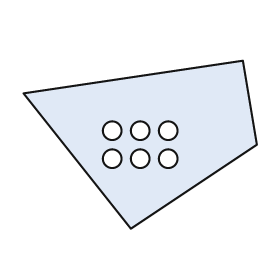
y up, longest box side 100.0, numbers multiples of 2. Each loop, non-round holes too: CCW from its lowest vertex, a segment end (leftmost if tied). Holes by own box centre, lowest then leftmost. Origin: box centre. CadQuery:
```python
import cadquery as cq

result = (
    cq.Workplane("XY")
    .moveTo(-4.0, -36.0)
    .lineTo(50.0, 0.0)
    .lineTo(44.0, 36.0)
    .lineTo(-50.0, 22.0)
    .close()
    .moveTo(-12.0, -6.0)
    .circle(4.0)
    .moveTo(0.0, -6.0)
    .circle(4.0)
    .moveTo(12.0, -6.0)
    .circle(4.0)
    .moveTo(-12.0, 6.0)
    .circle(4.0)
    .moveTo(0.0, 6.0)
    .circle(4.0)
    .moveTo(12.0, 6.0)
    .circle(4.0)
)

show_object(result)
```